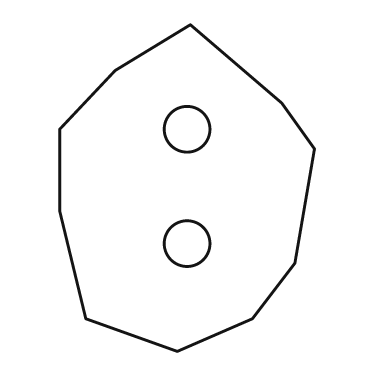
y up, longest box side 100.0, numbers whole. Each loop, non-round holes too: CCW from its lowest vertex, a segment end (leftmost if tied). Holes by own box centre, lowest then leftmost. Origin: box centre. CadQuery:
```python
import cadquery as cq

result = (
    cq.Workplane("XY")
    .moveTo(-3.0, -50.0)
    .lineTo(20.0, -40.0)
    .lineTo(33.0, -23.0)
    .lineTo(39.0, 12.0)
    .lineTo(29.0, 26.0)
    .lineTo(1.0, 50.0)
    .lineTo(-22.0, 36.0)
    .lineTo(-39.0, 18.0)
    .lineTo(-39.0, -7.0)
    .lineTo(-31.0, -40.0)
    .close()
    .moveTo(0.0, -17.0)
    .circle(7.0)
    .moveTo(0.0, 18.0)
    .circle(7.0)
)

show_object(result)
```